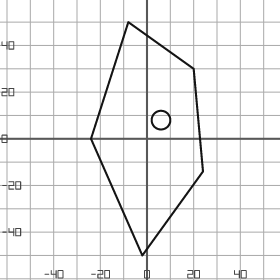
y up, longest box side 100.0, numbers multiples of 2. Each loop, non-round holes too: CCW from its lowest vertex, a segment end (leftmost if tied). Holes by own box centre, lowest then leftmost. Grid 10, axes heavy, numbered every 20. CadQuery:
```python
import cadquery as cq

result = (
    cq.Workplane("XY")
    .moveTo(-2.0, -50.0)
    .lineTo(24.0, -14.0)
    .lineTo(20.0, 30.0)
    .lineTo(-8.0, 50.0)
    .lineTo(-24.0, 0.0)
    .close()
    .moveTo(6.0, 8.0)
    .circle(4.0)
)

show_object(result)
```